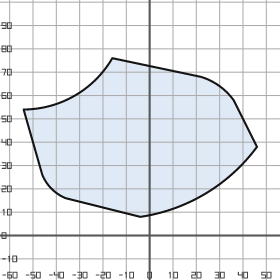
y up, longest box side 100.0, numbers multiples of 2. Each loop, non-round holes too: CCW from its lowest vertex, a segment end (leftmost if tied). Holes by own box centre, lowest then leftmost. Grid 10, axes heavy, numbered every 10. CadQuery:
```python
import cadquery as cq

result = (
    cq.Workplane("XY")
    .moveTo(-4.0, 8.0)
    .threePointArc((24.0, 18.0), (46.0, 38.0))
    .lineTo(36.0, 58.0)
    .threePointArc((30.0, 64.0), (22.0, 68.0))
    .lineTo(-16.0, 76.0)
    .threePointArc((-32.0, 60.0), (-54.0, 54.0))
    .lineTo(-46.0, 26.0)
    .threePointArc((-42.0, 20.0), (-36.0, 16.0))
    .close()
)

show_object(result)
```